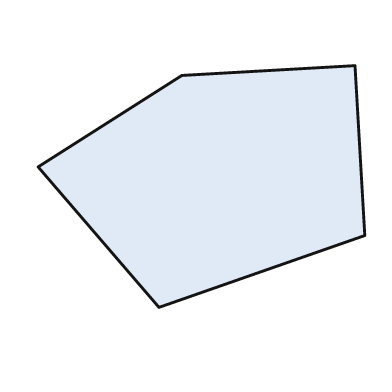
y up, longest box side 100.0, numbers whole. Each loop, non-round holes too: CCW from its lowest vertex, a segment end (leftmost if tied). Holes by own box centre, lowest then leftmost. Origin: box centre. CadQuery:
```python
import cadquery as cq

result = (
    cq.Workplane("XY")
    .moveTo(-13.0, -37.0)
    .lineTo(50.0, -15.0)
    .lineTo(47.0, 37.0)
    .lineTo(-6.0, 34.0)
    .lineTo(-50.0, 6.0)
    .close()
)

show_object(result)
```